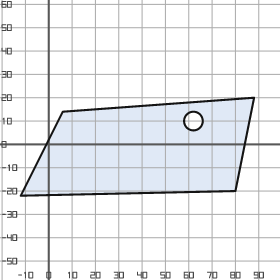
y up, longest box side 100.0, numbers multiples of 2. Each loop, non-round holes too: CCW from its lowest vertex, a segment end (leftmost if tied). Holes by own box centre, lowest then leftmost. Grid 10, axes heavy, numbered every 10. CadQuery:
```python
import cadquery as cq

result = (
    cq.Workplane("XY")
    .moveTo(-12.0, -22.0)
    .lineTo(80.0, -20.0)
    .lineTo(88.0, 20.0)
    .lineTo(6.0, 14.0)
    .close()
    .moveTo(62.0, 10.0)
    .circle(4.0)
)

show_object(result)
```